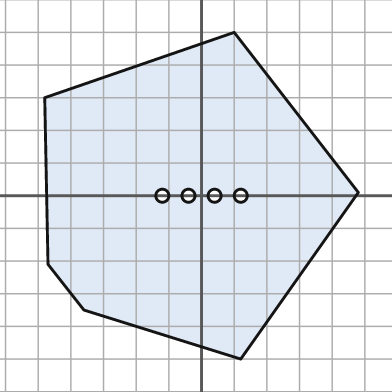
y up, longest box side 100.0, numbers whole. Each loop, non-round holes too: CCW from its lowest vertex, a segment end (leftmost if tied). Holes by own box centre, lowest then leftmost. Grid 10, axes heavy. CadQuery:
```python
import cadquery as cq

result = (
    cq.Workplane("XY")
    .moveTo(12.0, -50.0)
    .lineTo(48.0, 1.0)
    .lineTo(10.0, 50.0)
    .lineTo(-48.0, 30.0)
    .lineTo(-47.0, -21.0)
    .lineTo(-36.0, -35.0)
    .close()
    .moveTo(-12.0, 0.0)
    .circle(2.0)
    .moveTo(-4.0, 0.0)
    .circle(2.0)
    .moveTo(4.0, 0.0)
    .circle(2.0)
    .moveTo(12.0, 0.0)
    .circle(2.0)
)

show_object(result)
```